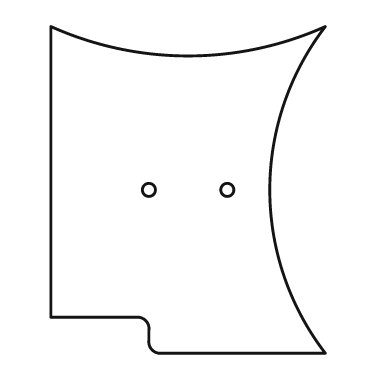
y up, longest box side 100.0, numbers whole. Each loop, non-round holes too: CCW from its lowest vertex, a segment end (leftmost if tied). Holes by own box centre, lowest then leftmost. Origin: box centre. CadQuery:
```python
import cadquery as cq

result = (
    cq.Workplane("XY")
    .moveTo(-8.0, -50.0)
    .lineTo(42.0, -50.0)
    .threePointArc((25.0, 0.0), (42.0, 50.0))
    .threePointArc((0.0, 41.0), (-42.0, 50.0))
    .lineTo(-42.0, -39.0)
    .lineTo(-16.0, -39.0)
    .threePointArc((-13.0, -40.0), (-12.0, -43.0))
    .lineTo(-12.0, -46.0)
    .threePointArc((-11.0, -49.0), (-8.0, -50.0))
    .close()
    .moveTo(-12.0, 0.0)
    .circle(2.0)
    .moveTo(12.0, 0.0)
    .circle(2.0)
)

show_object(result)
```